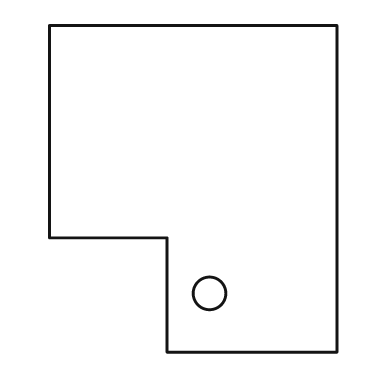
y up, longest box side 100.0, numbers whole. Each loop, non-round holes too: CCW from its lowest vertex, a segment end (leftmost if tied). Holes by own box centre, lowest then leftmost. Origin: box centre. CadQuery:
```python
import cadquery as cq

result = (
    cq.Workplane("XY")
    .moveTo(-8.0, -50.0)
    .lineTo(44.0, -50.0)
    .lineTo(44.0, 50.0)
    .lineTo(-44.0, 50.0)
    .lineTo(-44.0, -15.0)
    .lineTo(-8.0, -15.0)
    .close()
    .moveTo(5.0, -32.0)
    .circle(5.0)
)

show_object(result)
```